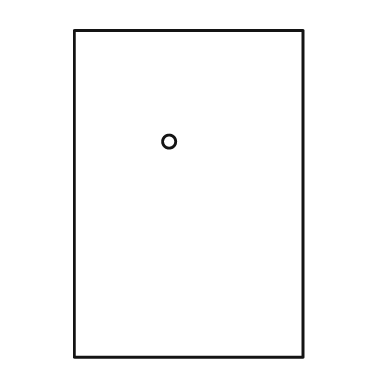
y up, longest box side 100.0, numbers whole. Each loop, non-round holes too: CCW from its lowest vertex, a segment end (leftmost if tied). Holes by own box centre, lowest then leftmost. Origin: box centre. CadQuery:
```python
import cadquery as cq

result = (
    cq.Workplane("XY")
    .moveTo(-35.0, -50.0)
    .lineTo(35.0, -50.0)
    .lineTo(35.0, 50.0)
    .lineTo(-35.0, 50.0)
    .close()
    .moveTo(-6.0, 16.0)
    .circle(2.0)
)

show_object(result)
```